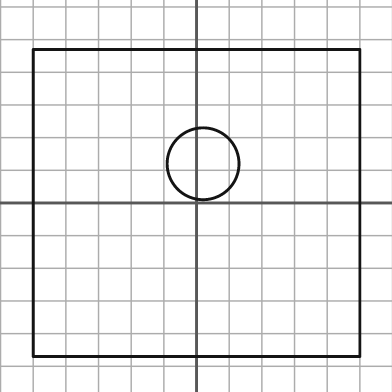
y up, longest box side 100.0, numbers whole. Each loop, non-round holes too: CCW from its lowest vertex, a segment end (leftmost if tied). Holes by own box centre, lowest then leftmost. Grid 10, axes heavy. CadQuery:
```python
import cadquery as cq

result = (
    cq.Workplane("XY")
    .moveTo(-50.0, -47.0)
    .lineTo(50.0, -47.0)
    .lineTo(50.0, 47.0)
    .lineTo(-50.0, 47.0)
    .close()
    .moveTo(2.0, 12.0)
    .circle(11.0)
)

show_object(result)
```